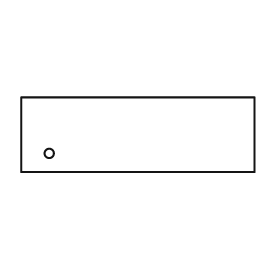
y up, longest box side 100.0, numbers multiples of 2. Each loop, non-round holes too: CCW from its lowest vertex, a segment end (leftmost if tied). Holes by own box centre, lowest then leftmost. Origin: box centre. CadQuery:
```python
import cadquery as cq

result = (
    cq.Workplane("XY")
    .moveTo(-50.0, -16.0)
    .lineTo(50.0, -16.0)
    .lineTo(50.0, 16.0)
    .lineTo(-50.0, 16.0)
    .close()
    .moveTo(-38.0, -8.0)
    .circle(2.0)
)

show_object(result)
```